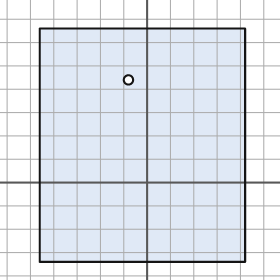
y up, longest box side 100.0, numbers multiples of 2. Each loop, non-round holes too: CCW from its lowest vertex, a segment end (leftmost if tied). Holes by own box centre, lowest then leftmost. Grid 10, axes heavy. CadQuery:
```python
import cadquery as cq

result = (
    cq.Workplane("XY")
    .moveTo(-46.0, -34.0)
    .lineTo(42.0, -34.0)
    .lineTo(42.0, 66.0)
    .lineTo(-46.0, 66.0)
    .close()
    .moveTo(-8.0, 44.0)
    .circle(2.0)
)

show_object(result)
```